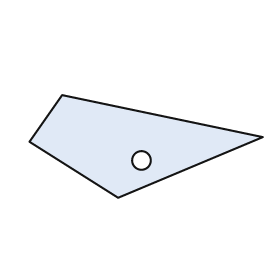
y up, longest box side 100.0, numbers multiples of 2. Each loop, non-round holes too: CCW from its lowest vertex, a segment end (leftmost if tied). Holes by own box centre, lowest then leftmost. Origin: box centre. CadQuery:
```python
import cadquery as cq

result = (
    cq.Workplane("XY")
    .moveTo(-12.0, -22.0)
    .lineTo(50.0, 4.0)
    .lineTo(-36.0, 22.0)
    .lineTo(-50.0, 2.0)
    .close()
    .moveTo(-2.0, -6.0)
    .circle(4.0)
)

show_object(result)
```